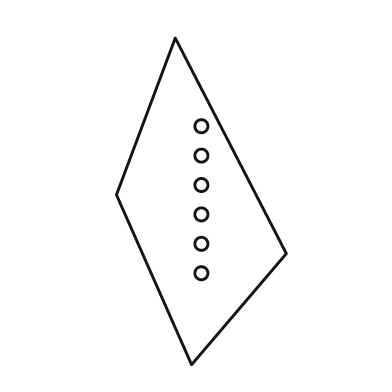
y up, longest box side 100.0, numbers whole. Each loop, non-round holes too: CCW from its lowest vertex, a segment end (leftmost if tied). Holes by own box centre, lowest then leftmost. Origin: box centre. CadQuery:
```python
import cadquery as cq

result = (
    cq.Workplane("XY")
    .moveTo(-3.0, -50.0)
    .lineTo(26.0, -16.0)
    .lineTo(-8.0, 50.0)
    .lineTo(-26.0, 2.0)
    .close()
    .moveTo(0.0, -22.0)
    .circle(2.0)
    .moveTo(0.0, -13.0)
    .circle(2.0)
    .moveTo(0.0, -4.0)
    .circle(2.0)
    .moveTo(0.0, 5.0)
    .circle(2.0)
    .moveTo(0.0, 14.0)
    .circle(2.0)
    .moveTo(0.0, 23.0)
    .circle(2.0)
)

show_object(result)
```